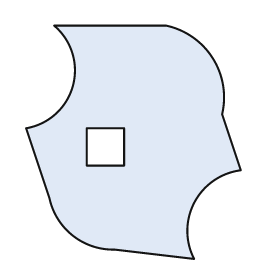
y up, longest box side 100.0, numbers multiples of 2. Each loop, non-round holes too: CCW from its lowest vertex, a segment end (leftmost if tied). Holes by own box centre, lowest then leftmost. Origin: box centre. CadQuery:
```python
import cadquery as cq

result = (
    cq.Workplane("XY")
    .moveTo(26.0, -50.0)
    .threePointArc((26.0, -26.0), (46.0, -12.0))
    .lineTo(38.0, 12.0)
    .threePointArc((34.0, 36.0), (14.0, 50.0))
    .lineTo(-34.0, 50.0)
    .threePointArc((-26.0, 24.0), (-46.0, 6.0))
    .lineTo(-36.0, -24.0)
    .threePointArc((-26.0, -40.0), (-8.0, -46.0))
    .close()
    .moveTo(-20.0, -10.0)
    .lineTo(-4.0, -10.0)
    .lineTo(-4.0, 6.0)
    .lineTo(-20.0, 6.0)
    .close()
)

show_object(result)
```